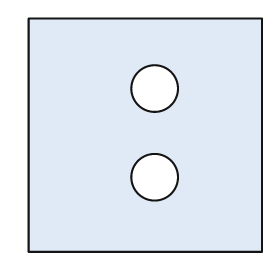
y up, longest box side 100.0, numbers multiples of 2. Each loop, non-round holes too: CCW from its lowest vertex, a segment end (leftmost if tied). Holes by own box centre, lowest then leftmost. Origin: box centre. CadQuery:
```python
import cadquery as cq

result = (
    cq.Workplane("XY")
    .moveTo(-50.0, -50.0)
    .lineTo(50.0, -50.0)
    .lineTo(50.0, 50.0)
    .lineTo(-50.0, 50.0)
    .close()
    .moveTo(4.0, -18.0)
    .circle(10.0)
    .moveTo(4.0, 20.0)
    .circle(10.0)
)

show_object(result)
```